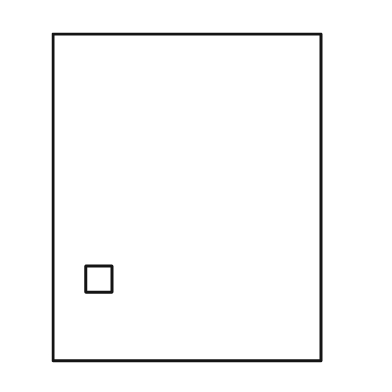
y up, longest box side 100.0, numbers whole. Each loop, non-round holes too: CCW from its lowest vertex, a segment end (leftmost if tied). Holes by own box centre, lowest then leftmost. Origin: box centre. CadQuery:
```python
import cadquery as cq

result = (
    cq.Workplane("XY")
    .moveTo(-41.0, -50.0)
    .lineTo(41.0, -50.0)
    .lineTo(41.0, 50.0)
    .lineTo(-41.0, 50.0)
    .close()
    .moveTo(-31.0, -29.0)
    .lineTo(-23.0, -29.0)
    .lineTo(-23.0, -21.0)
    .lineTo(-31.0, -21.0)
    .close()
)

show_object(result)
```